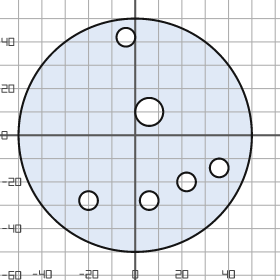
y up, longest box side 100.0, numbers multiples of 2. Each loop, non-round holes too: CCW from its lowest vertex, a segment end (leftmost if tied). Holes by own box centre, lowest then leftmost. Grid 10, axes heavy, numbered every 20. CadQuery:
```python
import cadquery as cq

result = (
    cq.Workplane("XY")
    .moveTo(0.0, 0.0)
    .circle(50.0)
    .moveTo(-20.0, -28.0)
    .circle(4.0)
    .moveTo(6.0, -28.0)
    .circle(4.0)
    .moveTo(22.0, -20.0)
    .circle(4.0)
    .moveTo(36.0, -14.0)
    .circle(4.0)
    .moveTo(6.0, 10.0)
    .circle(6.0)
    .moveTo(-4.0, 42.0)
    .circle(4.0)
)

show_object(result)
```